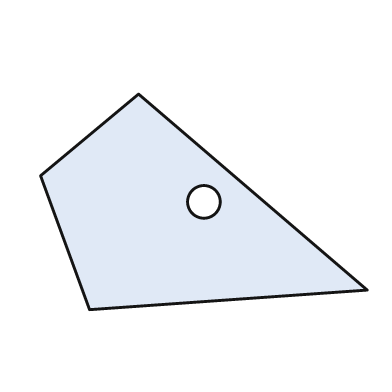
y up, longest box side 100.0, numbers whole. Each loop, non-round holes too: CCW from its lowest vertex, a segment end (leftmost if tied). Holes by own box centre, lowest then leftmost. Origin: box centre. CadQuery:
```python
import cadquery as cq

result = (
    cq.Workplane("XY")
    .moveTo(-35.0, -33.0)
    .lineTo(50.0, -27.0)
    .lineTo(-20.0, 33.0)
    .lineTo(-50.0, 8.0)
    .close()
    .moveTo(0.0, 0.0)
    .circle(5.0)
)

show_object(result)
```